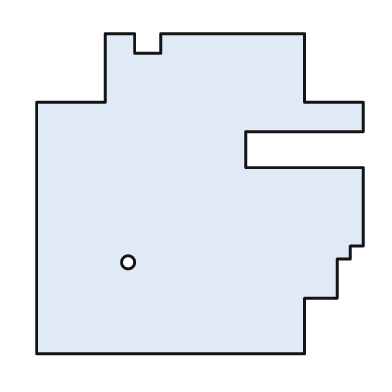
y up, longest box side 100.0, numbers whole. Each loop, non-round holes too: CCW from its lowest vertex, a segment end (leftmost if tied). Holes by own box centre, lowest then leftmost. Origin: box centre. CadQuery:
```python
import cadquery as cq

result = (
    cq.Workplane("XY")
    .moveTo(-50.0, -49.0)
    .lineTo(32.0, -49.0)
    .lineTo(32.0, -32.0)
    .lineTo(42.0, -32.0)
    .lineTo(42.0, -20.0)
    .lineTo(46.0, -20.0)
    .lineTo(46.0, -16.0)
    .lineTo(50.0, -16.0)
    .lineTo(50.0, 8.0)
    .lineTo(14.0, 8.0)
    .lineTo(14.0, 19.0)
    .lineTo(50.0, 19.0)
    .lineTo(50.0, 28.0)
    .lineTo(32.0, 28.0)
    .lineTo(32.0, 49.0)
    .lineTo(-12.0, 49.0)
    .lineTo(-12.0, 43.0)
    .lineTo(-20.0, 43.0)
    .lineTo(-20.0, 49.0)
    .lineTo(-29.0, 49.0)
    .lineTo(-29.0, 28.0)
    .lineTo(-50.0, 28.0)
    .close()
    .moveTo(-22.0, -21.0)
    .circle(2.0)
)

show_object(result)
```